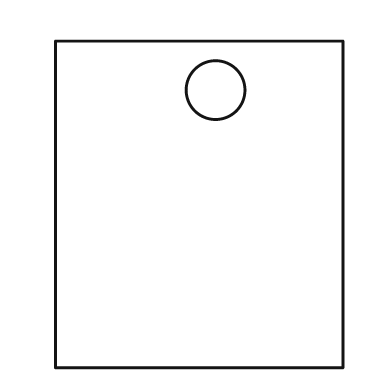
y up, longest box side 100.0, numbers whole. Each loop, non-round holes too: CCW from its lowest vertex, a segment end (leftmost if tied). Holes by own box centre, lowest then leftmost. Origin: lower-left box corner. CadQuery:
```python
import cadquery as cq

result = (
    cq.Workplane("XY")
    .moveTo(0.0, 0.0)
    .lineTo(88.0, 0.0)
    .lineTo(88.0, 100.0)
    .lineTo(0.0, 100.0)
    .close()
    .moveTo(49.0, 85.0)
    .circle(9.0)
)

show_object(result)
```